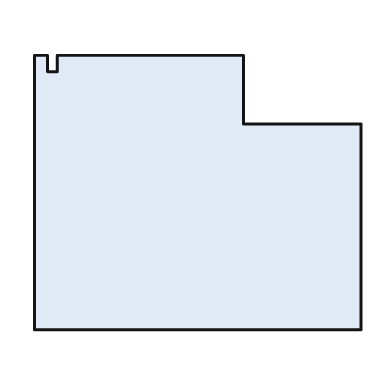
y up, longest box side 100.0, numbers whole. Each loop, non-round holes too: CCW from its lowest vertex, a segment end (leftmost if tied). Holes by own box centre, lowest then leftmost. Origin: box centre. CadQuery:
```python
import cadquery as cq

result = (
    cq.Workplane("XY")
    .moveTo(-50.0, -42.0)
    .lineTo(50.0, -42.0)
    .lineTo(50.0, 21.0)
    .lineTo(14.0, 21.0)
    .lineTo(14.0, 42.0)
    .lineTo(-43.0, 42.0)
    .lineTo(-43.0, 37.0)
    .lineTo(-46.0, 37.0)
    .lineTo(-46.0, 42.0)
    .lineTo(-50.0, 42.0)
    .close()
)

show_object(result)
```